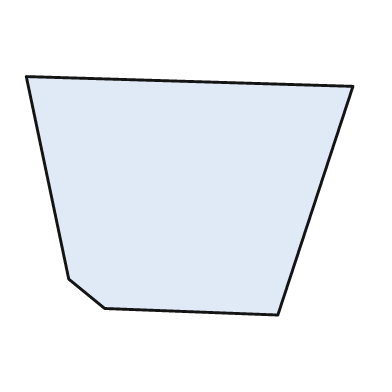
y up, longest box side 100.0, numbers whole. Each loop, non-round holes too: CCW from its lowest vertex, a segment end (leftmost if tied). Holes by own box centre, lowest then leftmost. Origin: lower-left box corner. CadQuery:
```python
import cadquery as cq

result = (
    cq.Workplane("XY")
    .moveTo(77.0, 0.0)
    .lineTo(100.0, 70.0)
    .lineTo(0.0, 73.0)
    .lineTo(13.0, 11.0)
    .lineTo(24.0, 2.0)
    .close()
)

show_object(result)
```